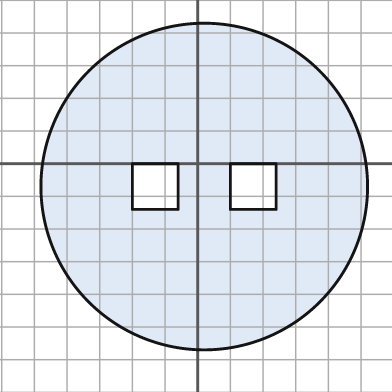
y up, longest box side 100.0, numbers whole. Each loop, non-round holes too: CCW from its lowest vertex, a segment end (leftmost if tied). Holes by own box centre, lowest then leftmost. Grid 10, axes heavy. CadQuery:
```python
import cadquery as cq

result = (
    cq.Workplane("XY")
    .moveTo(2.0, -7.0)
    .circle(50.0)
    .moveTo(-20.0, -14.0)
    .lineTo(-6.0, -14.0)
    .lineTo(-6.0, 0.0)
    .lineTo(-20.0, 0.0)
    .close()
    .moveTo(10.0, -14.0)
    .lineTo(24.0, -14.0)
    .lineTo(24.0, 0.0)
    .lineTo(10.0, 0.0)
    .close()
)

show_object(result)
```